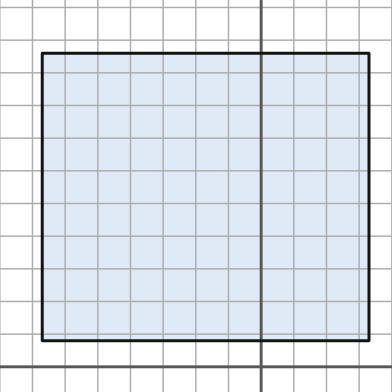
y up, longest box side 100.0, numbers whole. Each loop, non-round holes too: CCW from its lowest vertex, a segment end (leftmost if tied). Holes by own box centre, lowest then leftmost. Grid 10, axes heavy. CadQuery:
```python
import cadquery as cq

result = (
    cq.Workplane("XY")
    .moveTo(-67.0, 8.0)
    .lineTo(33.0, 8.0)
    .lineTo(33.0, 96.0)
    .lineTo(-67.0, 96.0)
    .close()
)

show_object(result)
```